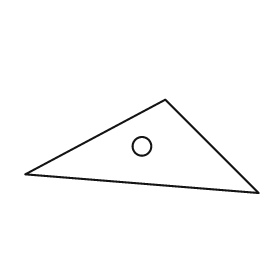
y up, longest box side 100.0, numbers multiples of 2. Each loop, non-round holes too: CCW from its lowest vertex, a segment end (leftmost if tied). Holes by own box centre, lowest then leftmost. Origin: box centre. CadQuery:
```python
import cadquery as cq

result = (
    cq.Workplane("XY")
    .moveTo(50.0, -20.0)
    .lineTo(10.0, 20.0)
    .lineTo(-50.0, -12.0)
    .close()
    .moveTo(0.0, 0.0)
    .circle(4.0)
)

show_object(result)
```